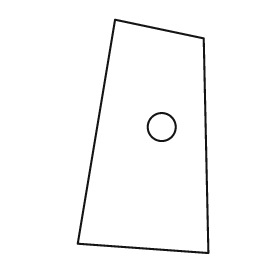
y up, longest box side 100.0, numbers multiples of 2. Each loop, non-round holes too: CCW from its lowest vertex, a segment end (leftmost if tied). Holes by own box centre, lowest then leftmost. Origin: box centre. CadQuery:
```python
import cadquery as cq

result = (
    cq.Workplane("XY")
    .moveTo(28.0, -50.0)
    .lineTo(26.0, 42.0)
    .lineTo(-12.0, 50.0)
    .lineTo(-28.0, -46.0)
    .close()
    .moveTo(8.0, 4.0)
    .circle(6.0)
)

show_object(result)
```